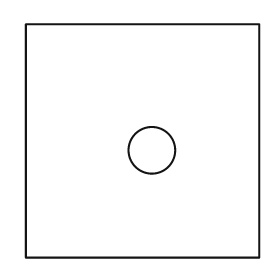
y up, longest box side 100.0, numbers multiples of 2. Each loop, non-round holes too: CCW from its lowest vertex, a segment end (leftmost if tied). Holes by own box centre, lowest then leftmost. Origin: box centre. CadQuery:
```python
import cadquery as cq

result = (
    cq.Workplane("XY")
    .moveTo(-50.0, -50.0)
    .lineTo(50.0, -50.0)
    .lineTo(50.0, 50.0)
    .lineTo(-50.0, 50.0)
    .close()
    .moveTo(4.0, -4.0)
    .circle(10.0)
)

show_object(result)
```